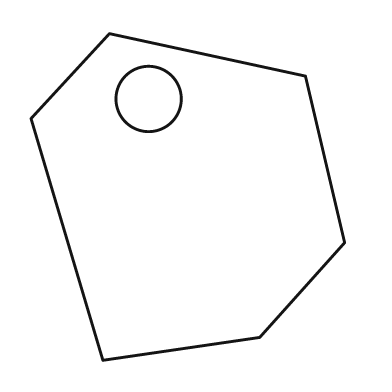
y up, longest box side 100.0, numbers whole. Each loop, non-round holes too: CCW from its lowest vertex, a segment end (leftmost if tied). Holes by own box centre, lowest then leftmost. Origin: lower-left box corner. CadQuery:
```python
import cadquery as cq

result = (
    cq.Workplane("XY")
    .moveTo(22.0, 0.0)
    .lineTo(70.0, 7.0)
    .lineTo(96.0, 36.0)
    .lineTo(84.0, 87.0)
    .lineTo(24.0, 100.0)
    .lineTo(0.0, 74.0)
    .close()
    .moveTo(36.0, 80.0)
    .circle(10.0)
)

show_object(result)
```